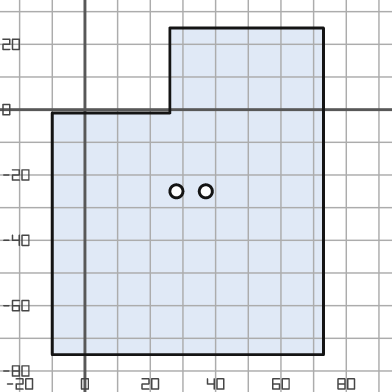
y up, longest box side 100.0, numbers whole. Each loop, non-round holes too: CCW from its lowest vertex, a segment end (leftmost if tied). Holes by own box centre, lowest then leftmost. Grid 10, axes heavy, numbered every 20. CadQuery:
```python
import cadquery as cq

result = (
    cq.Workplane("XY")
    .moveTo(-10.0, -75.0)
    .lineTo(73.0, -75.0)
    .lineTo(73.0, 25.0)
    .lineTo(26.0, 25.0)
    .lineTo(26.0, -1.0)
    .lineTo(-10.0, -1.0)
    .close()
    .moveTo(28.0, -25.0)
    .circle(2.0)
    .moveTo(37.0, -25.0)
    .circle(2.0)
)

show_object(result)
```